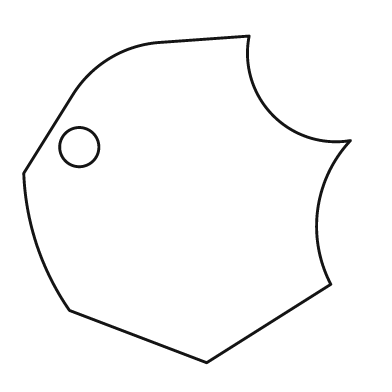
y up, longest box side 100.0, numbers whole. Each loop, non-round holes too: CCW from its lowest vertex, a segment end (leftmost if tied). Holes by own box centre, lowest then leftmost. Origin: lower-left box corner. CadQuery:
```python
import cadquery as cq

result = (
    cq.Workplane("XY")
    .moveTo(56.0, 0.0)
    .lineTo(94.0, 24.0)
    .threePointArc((90.0, 47.0), (100.0, 68.0))
    .threePointArc((76.0, 76.0), (69.0, 100.0))
    .lineTo(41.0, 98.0)
    .threePointArc((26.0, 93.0), (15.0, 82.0))
    .lineTo(0.0, 58.0)
    .threePointArc((4.0, 36.0), (14.0, 16.0))
    .close()
    .moveTo(17.0, 66.0)
    .circle(6.0)
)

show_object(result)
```